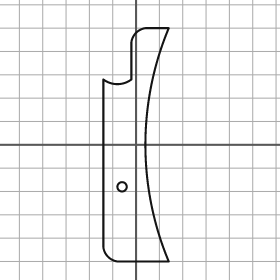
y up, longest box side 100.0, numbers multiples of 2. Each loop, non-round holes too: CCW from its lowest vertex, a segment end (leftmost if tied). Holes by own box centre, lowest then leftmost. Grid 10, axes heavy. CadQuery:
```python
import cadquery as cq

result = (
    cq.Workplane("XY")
    .moveTo(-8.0, -50.0)
    .lineTo(14.0, -50.0)
    .threePointArc((4.0, 0.0), (14.0, 50.0))
    .lineTo(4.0, 50.0)
    .threePointArc((0.0, 48.0), (-2.0, 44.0))
    .lineTo(-2.0, 28.0)
    .threePointArc((-8.0, 26.0), (-14.0, 28.0))
    .lineTo(-14.0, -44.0)
    .threePointArc((-12.0, -48.0), (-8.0, -50.0))
    .close()
    .moveTo(-6.0, -18.0)
    .circle(2.0)
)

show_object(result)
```